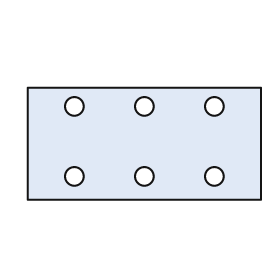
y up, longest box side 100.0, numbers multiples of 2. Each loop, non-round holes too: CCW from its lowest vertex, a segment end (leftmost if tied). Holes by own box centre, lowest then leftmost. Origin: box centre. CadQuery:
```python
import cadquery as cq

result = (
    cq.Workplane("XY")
    .moveTo(-50.0, -24.0)
    .lineTo(50.0, -24.0)
    .lineTo(50.0, 24.0)
    .lineTo(-50.0, 24.0)
    .close()
    .moveTo(-30.0, -14.0)
    .circle(4.0)
    .moveTo(0.0, -14.0)
    .circle(4.0)
    .moveTo(30.0, -14.0)
    .circle(4.0)
    .moveTo(-30.0, 16.0)
    .circle(4.0)
    .moveTo(0.0, 16.0)
    .circle(4.0)
    .moveTo(30.0, 16.0)
    .circle(4.0)
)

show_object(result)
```